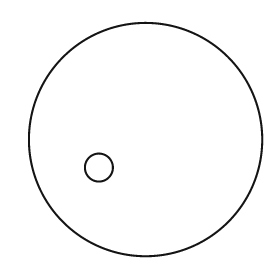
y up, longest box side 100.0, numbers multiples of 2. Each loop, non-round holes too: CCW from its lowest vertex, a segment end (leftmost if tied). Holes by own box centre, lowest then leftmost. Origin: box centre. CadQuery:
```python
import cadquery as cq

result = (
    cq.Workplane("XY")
    .moveTo(0.0, 0.0)
    .circle(50.0)
    .moveTo(-20.0, -12.0)
    .circle(6.0)
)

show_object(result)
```